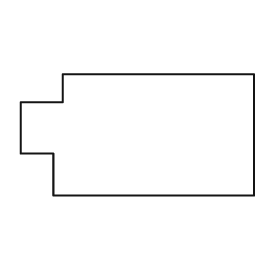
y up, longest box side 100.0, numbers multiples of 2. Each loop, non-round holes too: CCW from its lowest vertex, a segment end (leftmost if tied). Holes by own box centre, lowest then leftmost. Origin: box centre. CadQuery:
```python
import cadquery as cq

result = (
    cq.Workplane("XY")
    .moveTo(-36.0, -26.0)
    .lineTo(50.0, -26.0)
    .lineTo(50.0, 26.0)
    .lineTo(-32.0, 26.0)
    .lineTo(-32.0, 14.0)
    .lineTo(-50.0, 14.0)
    .lineTo(-50.0, -8.0)
    .lineTo(-36.0, -8.0)
    .close()
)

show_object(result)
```